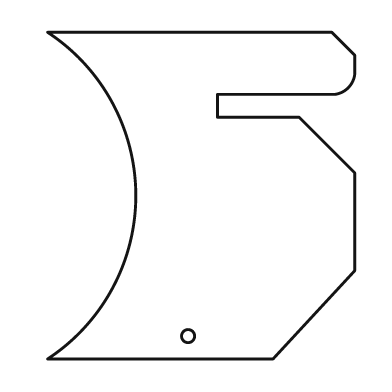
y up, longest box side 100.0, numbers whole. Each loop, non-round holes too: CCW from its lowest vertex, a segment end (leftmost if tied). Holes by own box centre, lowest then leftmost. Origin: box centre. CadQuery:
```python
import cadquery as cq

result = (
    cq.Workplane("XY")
    .moveTo(-47.0, -50.0)
    .lineTo(22.0, -50.0)
    .lineTo(47.0, -23.0)
    .lineTo(47.0, 7.0)
    .lineTo(30.0, 24.0)
    .lineTo(5.0, 24.0)
    .lineTo(5.0, 31.0)
    .lineTo(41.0, 31.0)
    .threePointArc((45.0, 33.0), (47.0, 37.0))
    .lineTo(47.0, 43.0)
    .lineTo(40.0, 50.0)
    .lineTo(-47.0, 50.0)
    .threePointArc((-20.0, 0.0), (-47.0, -50.0))
    .close()
    .moveTo(-4.0, -43.0)
    .circle(2.0)
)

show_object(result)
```